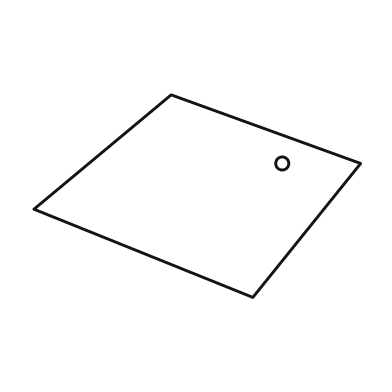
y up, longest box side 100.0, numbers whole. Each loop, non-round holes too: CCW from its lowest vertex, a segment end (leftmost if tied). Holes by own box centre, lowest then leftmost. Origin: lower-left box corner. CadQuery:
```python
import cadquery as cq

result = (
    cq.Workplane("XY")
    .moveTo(67.0, 0.0)
    .lineTo(100.0, 41.0)
    .lineTo(42.0, 62.0)
    .lineTo(0.0, 27.0)
    .close()
    .moveTo(76.0, 41.0)
    .circle(2.0)
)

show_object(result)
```